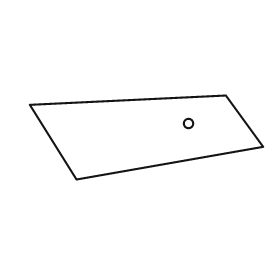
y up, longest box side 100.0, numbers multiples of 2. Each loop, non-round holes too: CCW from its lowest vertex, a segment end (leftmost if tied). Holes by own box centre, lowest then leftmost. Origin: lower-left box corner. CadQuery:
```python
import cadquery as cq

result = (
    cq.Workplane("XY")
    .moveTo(20.0, 0.0)
    .lineTo(100.0, 14.0)
    .lineTo(84.0, 36.0)
    .lineTo(0.0, 32.0)
    .close()
    .moveTo(68.0, 24.0)
    .circle(2.0)
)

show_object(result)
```